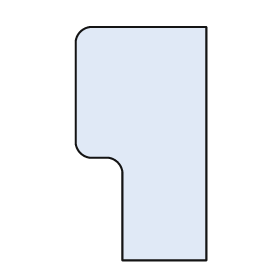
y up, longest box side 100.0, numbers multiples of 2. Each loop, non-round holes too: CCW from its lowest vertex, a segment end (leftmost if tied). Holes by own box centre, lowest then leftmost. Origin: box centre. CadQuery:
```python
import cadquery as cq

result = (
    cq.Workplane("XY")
    .moveTo(-8.0, -50.0)
    .lineTo(28.0, -50.0)
    .lineTo(28.0, 50.0)
    .lineTo(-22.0, 50.0)
    .threePointArc((-26.0, 48.0), (-28.0, 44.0))
    .lineTo(-28.0, 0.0)
    .threePointArc((-26.0, -4.0), (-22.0, -6.0))
    .lineTo(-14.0, -6.0)
    .threePointArc((-10.0, -8.0), (-8.0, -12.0))
    .close()
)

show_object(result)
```